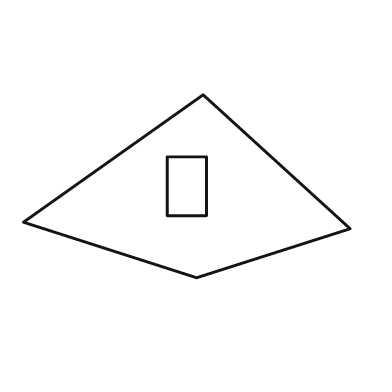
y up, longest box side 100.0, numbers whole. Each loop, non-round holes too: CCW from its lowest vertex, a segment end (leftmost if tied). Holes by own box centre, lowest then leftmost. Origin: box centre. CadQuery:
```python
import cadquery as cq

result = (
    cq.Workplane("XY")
    .moveTo(3.0, -28.0)
    .lineTo(50.0, -13.0)
    .lineTo(5.0, 28.0)
    .lineTo(-50.0, -11.0)
    .close()
    .moveTo(-6.0, -9.0)
    .lineTo(6.0, -9.0)
    .lineTo(6.0, 9.0)
    .lineTo(-6.0, 9.0)
    .close()
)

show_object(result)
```